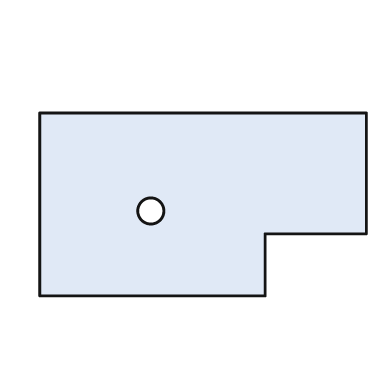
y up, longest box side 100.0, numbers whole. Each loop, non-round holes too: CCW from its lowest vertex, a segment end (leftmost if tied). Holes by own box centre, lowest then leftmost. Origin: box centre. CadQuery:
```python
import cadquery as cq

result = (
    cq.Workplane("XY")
    .moveTo(-50.0, -28.0)
    .lineTo(19.0, -28.0)
    .lineTo(19.0, -9.0)
    .lineTo(50.0, -9.0)
    .lineTo(50.0, 28.0)
    .lineTo(-50.0, 28.0)
    .close()
    .moveTo(-16.0, -2.0)
    .circle(4.0)
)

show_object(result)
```